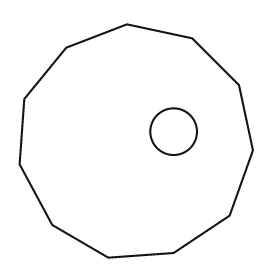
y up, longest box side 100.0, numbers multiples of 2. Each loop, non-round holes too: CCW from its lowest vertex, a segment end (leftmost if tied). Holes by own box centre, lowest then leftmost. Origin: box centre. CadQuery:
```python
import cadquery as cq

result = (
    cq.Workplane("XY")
    .moveTo(-12.0, -50.0)
    .lineTo(16.0, -48.0)
    .lineTo(40.0, -32.0)
    .lineTo(50.0, -4.0)
    .lineTo(44.0, 24.0)
    .lineTo(24.0, 44.0)
    .lineTo(-4.0, 50.0)
    .lineTo(-30.0, 40.0)
    .lineTo(-48.0, 18.0)
    .lineTo(-50.0, -10.0)
    .lineTo(-36.0, -36.0)
    .close()
    .moveTo(16.0, 4.0)
    .circle(10.0)
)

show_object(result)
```